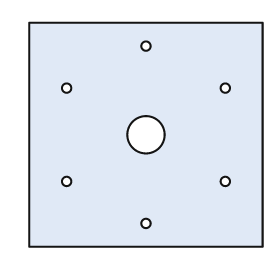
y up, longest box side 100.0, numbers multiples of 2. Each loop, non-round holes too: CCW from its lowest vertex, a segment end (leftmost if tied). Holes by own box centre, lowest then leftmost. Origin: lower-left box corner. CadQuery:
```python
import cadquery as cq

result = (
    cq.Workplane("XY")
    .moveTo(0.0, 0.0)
    .lineTo(100.0, 0.0)
    .lineTo(100.0, 96.0)
    .lineTo(0.0, 96.0)
    .close()
    .moveTo(50.0, 10.0)
    .circle(2.0)
    .moveTo(16.0, 28.0)
    .circle(2.0)
    .moveTo(84.0, 28.0)
    .circle(2.0)
    .moveTo(50.0, 48.0)
    .circle(8.0)
    .moveTo(16.0, 68.0)
    .circle(2.0)
    .moveTo(84.0, 68.0)
    .circle(2.0)
    .moveTo(50.0, 86.0)
    .circle(2.0)
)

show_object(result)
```